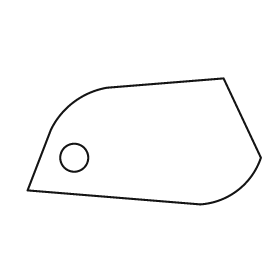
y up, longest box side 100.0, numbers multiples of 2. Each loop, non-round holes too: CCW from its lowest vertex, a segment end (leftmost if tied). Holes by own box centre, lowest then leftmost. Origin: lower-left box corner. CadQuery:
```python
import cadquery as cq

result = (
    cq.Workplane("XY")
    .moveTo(74.0, 0.0)
    .threePointArc((90.0, 6.0), (100.0, 20.0))
    .lineTo(84.0, 54.0)
    .lineTo(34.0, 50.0)
    .threePointArc((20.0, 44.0), (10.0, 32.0))
    .lineTo(0.0, 6.0)
    .close()
    .moveTo(20.0, 20.0)
    .circle(6.0)
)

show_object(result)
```